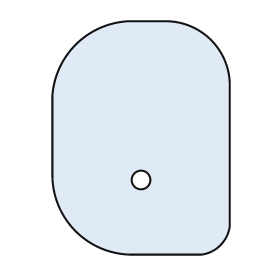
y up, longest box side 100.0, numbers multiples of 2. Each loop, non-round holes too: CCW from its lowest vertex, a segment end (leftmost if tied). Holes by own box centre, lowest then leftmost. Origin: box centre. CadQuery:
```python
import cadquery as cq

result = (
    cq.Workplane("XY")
    .moveTo(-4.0, -50.0)
    .lineTo(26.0, -50.0)
    .threePointArc((34.0, -46.0), (38.0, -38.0))
    .lineTo(38.0, 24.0)
    .threePointArc((30.0, 42.0), (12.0, 50.0))
    .lineTo(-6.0, 50.0)
    .threePointArc((-28.0, 40.0), (-38.0, 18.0))
    .lineTo(-38.0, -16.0)
    .threePointArc((-28.0, -40.0), (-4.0, -50.0))
    .close()
    .moveTo(0.0, -18.0)
    .circle(4.0)
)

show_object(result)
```